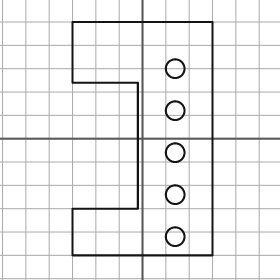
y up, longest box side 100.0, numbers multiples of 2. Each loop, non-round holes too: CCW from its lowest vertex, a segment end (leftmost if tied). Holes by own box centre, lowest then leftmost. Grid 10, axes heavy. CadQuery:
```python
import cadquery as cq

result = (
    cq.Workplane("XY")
    .moveTo(-30.0, -50.0)
    .lineTo(30.0, -50.0)
    .lineTo(30.0, 50.0)
    .lineTo(-30.0, 50.0)
    .lineTo(-30.0, 24.0)
    .lineTo(-2.0, 24.0)
    .lineTo(-2.0, -30.0)
    .lineTo(-30.0, -30.0)
    .close()
    .moveTo(14.0, -42.0)
    .circle(4.0)
    .moveTo(14.0, -24.0)
    .circle(4.0)
    .moveTo(14.0, -6.0)
    .circle(4.0)
    .moveTo(14.0, 12.0)
    .circle(4.0)
    .moveTo(14.0, 30.0)
    .circle(4.0)
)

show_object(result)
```